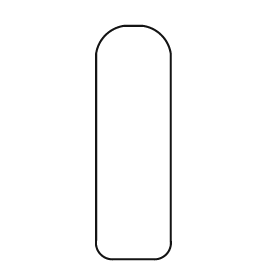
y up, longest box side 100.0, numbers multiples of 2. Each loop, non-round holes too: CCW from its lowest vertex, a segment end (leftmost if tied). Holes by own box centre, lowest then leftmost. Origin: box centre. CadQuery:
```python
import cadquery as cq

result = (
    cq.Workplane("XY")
    .moveTo(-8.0, -50.0)
    .lineTo(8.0, -50.0)
    .threePointArc((14.0, -48.0), (16.0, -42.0))
    .lineTo(16.0, 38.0)
    .threePointArc((12.0, 46.0), (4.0, 50.0))
    .lineTo(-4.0, 50.0)
    .threePointArc((-12.0, 46.0), (-16.0, 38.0))
    .lineTo(-16.0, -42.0)
    .threePointArc((-14.0, -48.0), (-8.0, -50.0))
    .close()
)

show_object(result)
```